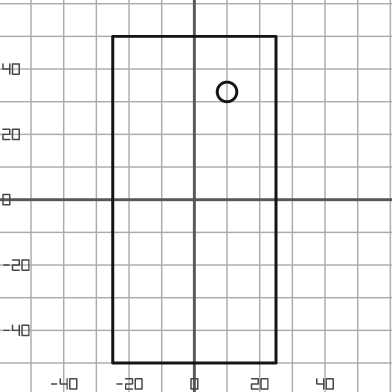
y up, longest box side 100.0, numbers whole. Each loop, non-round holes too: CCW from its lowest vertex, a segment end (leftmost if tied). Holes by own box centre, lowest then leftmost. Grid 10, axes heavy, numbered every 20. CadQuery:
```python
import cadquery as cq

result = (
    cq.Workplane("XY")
    .moveTo(-25.0, -50.0)
    .lineTo(25.0, -50.0)
    .lineTo(25.0, 50.0)
    .lineTo(-25.0, 50.0)
    .close()
    .moveTo(10.0, 33.0)
    .circle(3.0)
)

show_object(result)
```